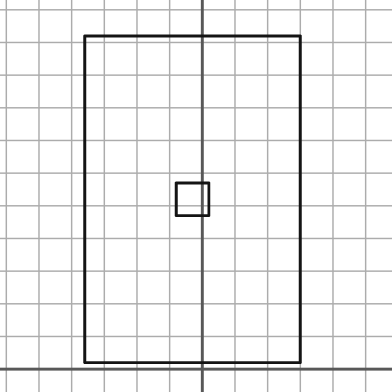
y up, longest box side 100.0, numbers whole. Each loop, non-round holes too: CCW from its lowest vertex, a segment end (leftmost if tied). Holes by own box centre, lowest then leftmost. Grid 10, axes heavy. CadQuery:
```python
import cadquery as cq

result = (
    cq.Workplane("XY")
    .moveTo(-36.0, 2.0)
    .lineTo(30.0, 2.0)
    .lineTo(30.0, 102.0)
    .lineTo(-36.0, 102.0)
    .close()
    .moveTo(-8.0, 47.0)
    .lineTo(2.0, 47.0)
    .lineTo(2.0, 57.0)
    .lineTo(-8.0, 57.0)
    .close()
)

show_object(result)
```